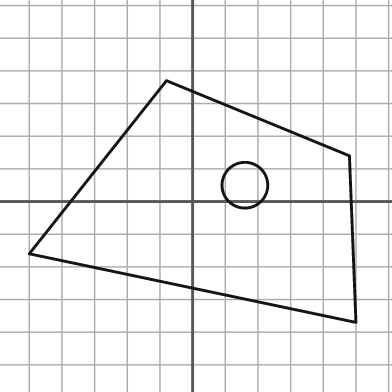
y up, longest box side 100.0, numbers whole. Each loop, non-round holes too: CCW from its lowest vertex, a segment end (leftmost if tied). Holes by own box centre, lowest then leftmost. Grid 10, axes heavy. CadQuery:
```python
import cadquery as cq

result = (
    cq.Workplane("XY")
    .moveTo(50.0, -37.0)
    .lineTo(48.0, 14.0)
    .lineTo(-8.0, 37.0)
    .lineTo(-50.0, -16.0)
    .close()
    .moveTo(16.0, 5.0)
    .circle(7.0)
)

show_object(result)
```